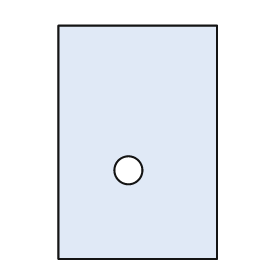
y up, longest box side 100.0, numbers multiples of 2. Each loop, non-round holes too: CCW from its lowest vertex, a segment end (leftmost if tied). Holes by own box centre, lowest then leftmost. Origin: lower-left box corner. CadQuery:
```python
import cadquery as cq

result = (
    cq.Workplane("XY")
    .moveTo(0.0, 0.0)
    .lineTo(68.0, 0.0)
    .lineTo(68.0, 100.0)
    .lineTo(0.0, 100.0)
    .close()
    .moveTo(30.0, 38.0)
    .circle(6.0)
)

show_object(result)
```